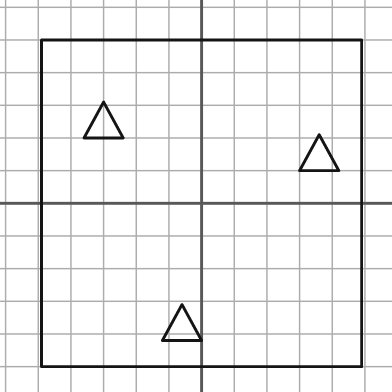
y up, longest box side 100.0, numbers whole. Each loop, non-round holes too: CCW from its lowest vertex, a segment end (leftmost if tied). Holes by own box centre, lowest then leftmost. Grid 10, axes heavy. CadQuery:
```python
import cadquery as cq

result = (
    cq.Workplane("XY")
    .moveTo(-49.0, -50.0)
    .lineTo(49.0, -50.0)
    .lineTo(49.0, 50.0)
    .lineTo(-49.0, 50.0)
    .close()
    .moveTo(-12.0, -42.0)
    .lineTo(0.0, -42.0)
    .lineTo(-6.0, -31.0)
    .close()
    .moveTo(30.0, 10.0)
    .lineTo(42.0, 10.0)
    .lineTo(36.0, 21.0)
    .close()
    .moveTo(-36.0, 20.0)
    .lineTo(-24.0, 20.0)
    .lineTo(-30.0, 31.0)
    .close()
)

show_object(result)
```